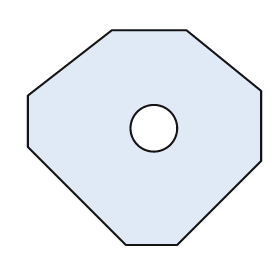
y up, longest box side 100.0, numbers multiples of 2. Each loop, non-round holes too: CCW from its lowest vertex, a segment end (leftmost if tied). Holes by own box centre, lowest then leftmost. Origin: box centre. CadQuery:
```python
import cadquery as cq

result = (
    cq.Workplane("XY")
    .moveTo(-8.0, -46.0)
    .lineTo(14.0, -46.0)
    .lineTo(50.0, -10.0)
    .lineTo(50.0, 20.0)
    .lineTo(18.0, 46.0)
    .lineTo(-14.0, 46.0)
    .lineTo(-50.0, 18.0)
    .lineTo(-50.0, -4.0)
    .close()
    .moveTo(4.0, 4.0)
    .circle(10.0)
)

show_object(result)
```